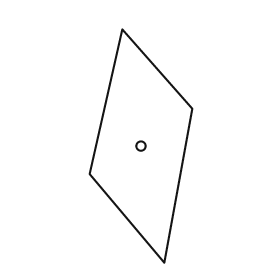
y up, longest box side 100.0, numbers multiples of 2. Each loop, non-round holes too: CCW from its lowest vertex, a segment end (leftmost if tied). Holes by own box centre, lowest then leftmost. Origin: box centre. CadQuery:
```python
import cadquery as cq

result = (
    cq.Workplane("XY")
    .moveTo(10.0, -50.0)
    .lineTo(22.0, 16.0)
    .lineTo(-8.0, 50.0)
    .lineTo(-22.0, -12.0)
    .close()
    .moveTo(0.0, 0.0)
    .circle(2.0)
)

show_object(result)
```